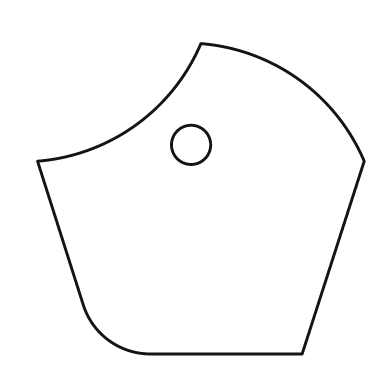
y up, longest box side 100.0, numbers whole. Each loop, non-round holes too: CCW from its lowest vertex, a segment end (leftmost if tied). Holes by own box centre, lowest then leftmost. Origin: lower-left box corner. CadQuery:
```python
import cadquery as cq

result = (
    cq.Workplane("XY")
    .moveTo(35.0, 0.0)
    .lineTo(81.0, 0.0)
    .lineTo(100.0, 59.0)
    .threePointArc((80.0, 84.0), (50.0, 95.0))
    .threePointArc((30.0, 70.0), (0.0, 59.0))
    .lineTo(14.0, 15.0)
    .threePointArc((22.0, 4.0), (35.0, 0.0))
    .close()
    .moveTo(47.0, 64.0)
    .circle(6.0)
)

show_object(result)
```